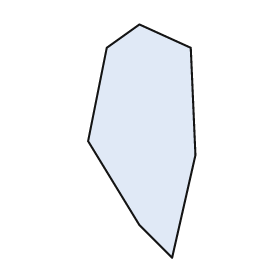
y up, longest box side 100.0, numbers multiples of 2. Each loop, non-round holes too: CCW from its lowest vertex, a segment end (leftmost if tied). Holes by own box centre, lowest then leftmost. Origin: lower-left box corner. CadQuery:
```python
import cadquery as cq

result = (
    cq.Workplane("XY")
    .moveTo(36.0, 0.0)
    .lineTo(46.0, 44.0)
    .lineTo(44.0, 90.0)
    .lineTo(22.0, 100.0)
    .lineTo(8.0, 90.0)
    .lineTo(0.0, 50.0)
    .lineTo(22.0, 14.0)
    .close()
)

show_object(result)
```